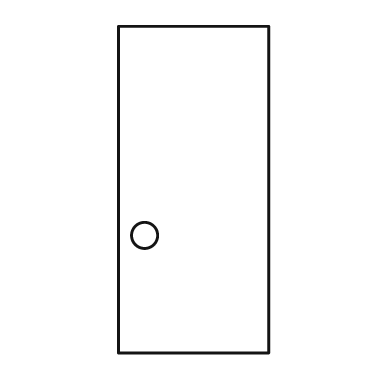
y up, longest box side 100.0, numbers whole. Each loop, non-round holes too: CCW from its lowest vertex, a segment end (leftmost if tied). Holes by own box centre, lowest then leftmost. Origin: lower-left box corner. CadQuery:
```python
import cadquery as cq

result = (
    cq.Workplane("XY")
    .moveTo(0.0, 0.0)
    .lineTo(46.0, 0.0)
    .lineTo(46.0, 100.0)
    .lineTo(0.0, 100.0)
    .close()
    .moveTo(8.0, 36.0)
    .circle(4.0)
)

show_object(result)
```